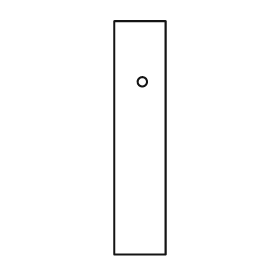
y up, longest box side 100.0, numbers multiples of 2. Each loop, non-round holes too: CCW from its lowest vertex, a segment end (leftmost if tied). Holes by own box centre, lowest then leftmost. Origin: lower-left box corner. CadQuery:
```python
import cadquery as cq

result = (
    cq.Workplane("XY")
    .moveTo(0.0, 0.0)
    .lineTo(22.0, 0.0)
    .lineTo(22.0, 100.0)
    .lineTo(0.0, 100.0)
    .close()
    .moveTo(12.0, 74.0)
    .circle(2.0)
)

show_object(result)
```